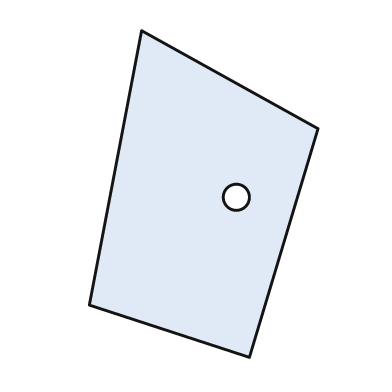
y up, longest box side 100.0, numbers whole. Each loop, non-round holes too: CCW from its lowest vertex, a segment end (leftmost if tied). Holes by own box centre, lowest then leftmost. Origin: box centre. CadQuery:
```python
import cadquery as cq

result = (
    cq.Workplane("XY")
    .moveTo(14.0, -50.0)
    .lineTo(35.0, 20.0)
    .lineTo(-19.0, 50.0)
    .lineTo(-35.0, -34.0)
    .close()
    .moveTo(10.0, -1.0)
    .circle(4.0)
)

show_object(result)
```